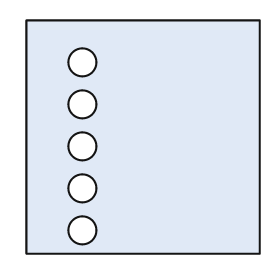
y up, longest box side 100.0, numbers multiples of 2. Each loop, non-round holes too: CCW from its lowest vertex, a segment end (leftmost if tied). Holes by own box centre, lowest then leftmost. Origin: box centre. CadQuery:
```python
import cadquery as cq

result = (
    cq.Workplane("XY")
    .moveTo(-50.0, -50.0)
    .lineTo(50.0, -50.0)
    .lineTo(50.0, 50.0)
    .lineTo(-50.0, 50.0)
    .close()
    .moveTo(-26.0, -40.0)
    .circle(6.0)
    .moveTo(-26.0, -22.0)
    .circle(6.0)
    .moveTo(-26.0, -4.0)
    .circle(6.0)
    .moveTo(-26.0, 14.0)
    .circle(6.0)
    .moveTo(-26.0, 32.0)
    .circle(6.0)
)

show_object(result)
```